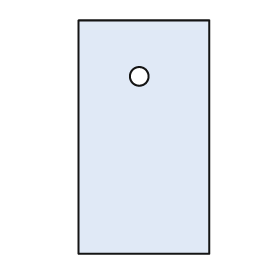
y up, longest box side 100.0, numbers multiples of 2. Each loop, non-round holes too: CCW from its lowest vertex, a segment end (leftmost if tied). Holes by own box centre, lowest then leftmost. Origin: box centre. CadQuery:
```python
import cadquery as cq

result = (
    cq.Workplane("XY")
    .moveTo(-28.0, -50.0)
    .lineTo(28.0, -50.0)
    .lineTo(28.0, 50.0)
    .lineTo(-28.0, 50.0)
    .close()
    .moveTo(-2.0, 26.0)
    .circle(4.0)
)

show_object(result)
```